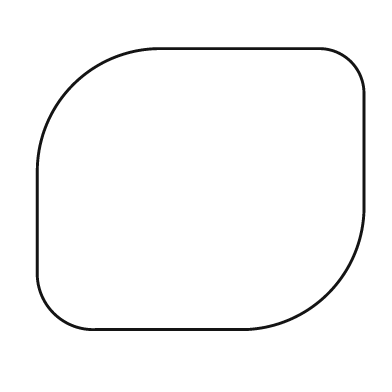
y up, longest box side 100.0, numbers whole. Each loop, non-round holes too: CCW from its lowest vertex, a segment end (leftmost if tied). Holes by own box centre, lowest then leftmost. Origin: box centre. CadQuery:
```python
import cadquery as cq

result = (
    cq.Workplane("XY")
    .moveTo(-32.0, -43.0)
    .lineTo(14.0, -43.0)
    .threePointArc((39.0, -32.0), (50.0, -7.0))
    .lineTo(50.0, 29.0)
    .threePointArc((46.0, 39.0), (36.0, 43.0))
    .lineTo(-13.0, 43.0)
    .threePointArc((-39.0, 32.0), (-50.0, 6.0))
    .lineTo(-50.0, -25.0)
    .threePointArc((-45.0, -38.0), (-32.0, -43.0))
    .close()
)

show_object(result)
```